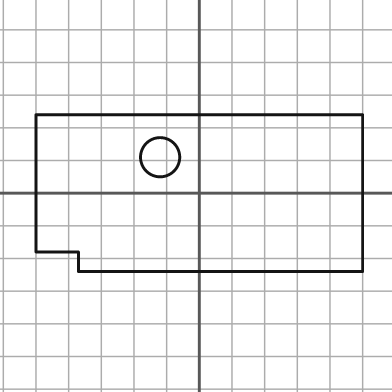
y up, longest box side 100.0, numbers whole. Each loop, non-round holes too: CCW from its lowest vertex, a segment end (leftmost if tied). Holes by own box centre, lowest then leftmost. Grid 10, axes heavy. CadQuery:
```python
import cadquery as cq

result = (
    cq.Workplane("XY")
    .moveTo(-37.0, -24.0)
    .lineTo(50.0, -24.0)
    .lineTo(50.0, 24.0)
    .lineTo(-50.0, 24.0)
    .lineTo(-50.0, -18.0)
    .lineTo(-37.0, -18.0)
    .close()
    .moveTo(-12.0, 11.0)
    .circle(6.0)
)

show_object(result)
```